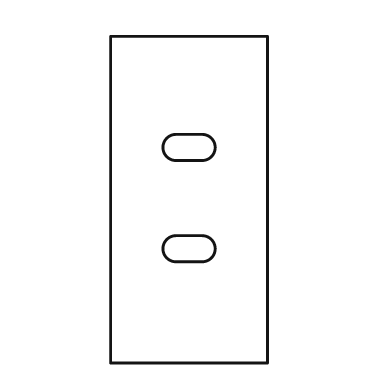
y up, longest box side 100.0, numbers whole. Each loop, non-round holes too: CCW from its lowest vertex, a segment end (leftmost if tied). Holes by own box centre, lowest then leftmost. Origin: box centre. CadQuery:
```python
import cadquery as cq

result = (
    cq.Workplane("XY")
    .moveTo(-24.0, -50.0)
    .lineTo(24.0, -50.0)
    .lineTo(24.0, 50.0)
    .lineTo(-24.0, 50.0)
    .close()
    .moveTo(-4.0, -19.0)
    .lineTo(4.0, -19.0)
    .threePointArc((8.0, -15.0), (4.0, -11.0))
    .lineTo(-4.0, -11.0)
    .threePointArc((-8.0, -15.0), (-4.0, -19.0))
    .close()
    .moveTo(-4.0, 12.0)
    .lineTo(4.0, 12.0)
    .threePointArc((8.0, 16.0), (4.0, 20.0))
    .lineTo(-4.0, 20.0)
    .threePointArc((-8.0, 16.0), (-4.0, 12.0))
    .close()
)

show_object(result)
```